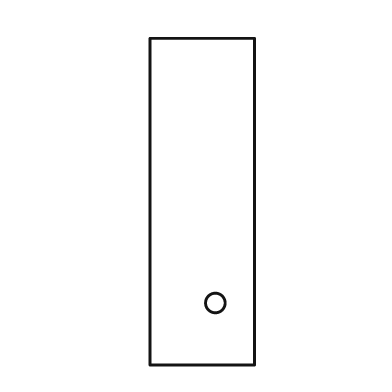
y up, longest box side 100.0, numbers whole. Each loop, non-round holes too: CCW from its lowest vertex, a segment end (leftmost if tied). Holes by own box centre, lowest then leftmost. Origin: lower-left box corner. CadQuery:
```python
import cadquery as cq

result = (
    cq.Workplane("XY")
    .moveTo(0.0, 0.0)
    .lineTo(32.0, 0.0)
    .lineTo(32.0, 100.0)
    .lineTo(0.0, 100.0)
    .close()
    .moveTo(20.0, 19.0)
    .circle(3.0)
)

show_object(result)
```